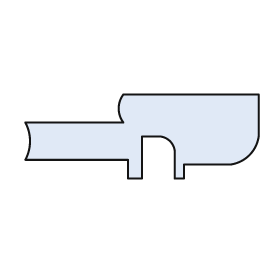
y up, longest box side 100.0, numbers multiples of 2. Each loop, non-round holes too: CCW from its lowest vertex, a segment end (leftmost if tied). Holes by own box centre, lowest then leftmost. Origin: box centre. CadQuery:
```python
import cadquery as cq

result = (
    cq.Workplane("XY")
    .moveTo(-6.0, -18.0)
    .lineTo(0.0, -18.0)
    .lineTo(0.0, 0.0)
    .lineTo(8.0, 0.0)
    .threePointArc((12.0, -2.0), (14.0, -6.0))
    .lineTo(14.0, -18.0)
    .lineTo(18.0, -18.0)
    .lineTo(18.0, -12.0)
    .lineTo(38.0, -12.0)
    .threePointArc((46.0, -8.0), (50.0, 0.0))
    .lineTo(50.0, 18.0)
    .lineTo(-8.0, 18.0)
    .threePointArc((-10.0, 12.0), (-8.0, 6.0))
    .lineTo(-50.0, 6.0)
    .threePointArc((-48.0, -2.0), (-50.0, -10.0))
    .lineTo(-6.0, -10.0)
    .close()
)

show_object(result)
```